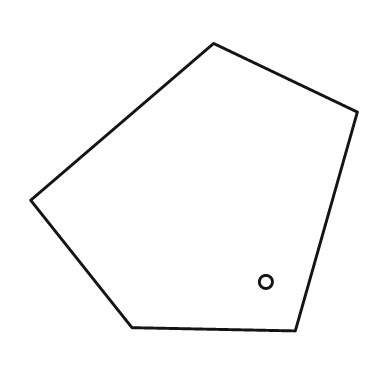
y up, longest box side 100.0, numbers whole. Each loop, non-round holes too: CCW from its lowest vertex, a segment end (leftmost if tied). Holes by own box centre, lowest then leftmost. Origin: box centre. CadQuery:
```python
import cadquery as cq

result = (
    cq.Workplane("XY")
    .moveTo(31.0, -44.0)
    .lineTo(50.0, 23.0)
    .lineTo(6.0, 44.0)
    .lineTo(-50.0, -4.0)
    .lineTo(-19.0, -43.0)
    .close()
    .moveTo(22.0, -29.0)
    .circle(2.0)
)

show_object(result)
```